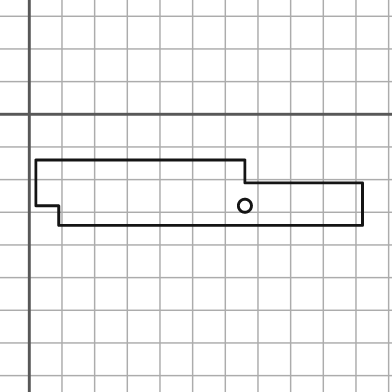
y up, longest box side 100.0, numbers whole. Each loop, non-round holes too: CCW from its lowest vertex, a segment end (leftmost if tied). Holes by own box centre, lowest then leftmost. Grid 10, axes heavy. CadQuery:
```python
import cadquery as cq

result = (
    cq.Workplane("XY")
    .moveTo(9.0, -34.0)
    .lineTo(102.0, -34.0)
    .lineTo(102.0, -21.0)
    .lineTo(66.0, -21.0)
    .lineTo(66.0, -14.0)
    .lineTo(2.0, -14.0)
    .lineTo(2.0, -28.0)
    .lineTo(9.0, -28.0)
    .close()
    .moveTo(66.0, -28.0)
    .circle(2.0)
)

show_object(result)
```